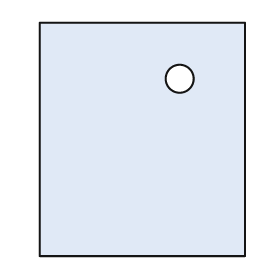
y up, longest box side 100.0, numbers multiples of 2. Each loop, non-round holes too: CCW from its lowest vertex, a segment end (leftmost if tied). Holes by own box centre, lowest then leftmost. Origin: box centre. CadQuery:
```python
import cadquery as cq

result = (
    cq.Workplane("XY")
    .moveTo(-44.0, -50.0)
    .lineTo(44.0, -50.0)
    .lineTo(44.0, 50.0)
    .lineTo(-44.0, 50.0)
    .close()
    .moveTo(16.0, 26.0)
    .circle(6.0)
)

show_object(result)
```